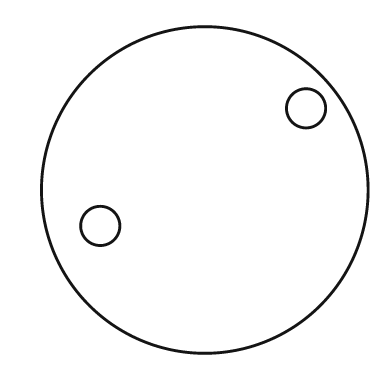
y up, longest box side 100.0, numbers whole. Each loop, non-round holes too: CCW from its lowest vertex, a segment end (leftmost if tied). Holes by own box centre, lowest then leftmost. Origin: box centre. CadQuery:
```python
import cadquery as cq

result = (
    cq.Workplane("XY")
    .moveTo(0.0, 0.0)
    .circle(50.0)
    .moveTo(-32.0, -11.0)
    .circle(6.0)
    .moveTo(31.0, 25.0)
    .circle(6.0)
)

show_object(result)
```